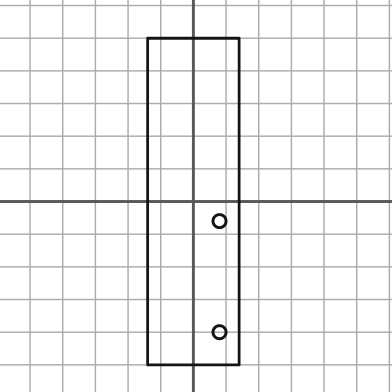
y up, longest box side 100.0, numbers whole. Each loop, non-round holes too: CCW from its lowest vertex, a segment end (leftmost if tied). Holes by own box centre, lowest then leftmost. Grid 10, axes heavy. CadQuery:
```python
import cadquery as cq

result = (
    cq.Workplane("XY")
    .moveTo(-14.0, -50.0)
    .lineTo(14.0, -50.0)
    .lineTo(14.0, 50.0)
    .lineTo(-14.0, 50.0)
    .close()
    .moveTo(8.0, -40.0)
    .circle(2.0)
    .moveTo(8.0, -6.0)
    .circle(2.0)
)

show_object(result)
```